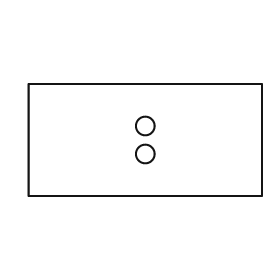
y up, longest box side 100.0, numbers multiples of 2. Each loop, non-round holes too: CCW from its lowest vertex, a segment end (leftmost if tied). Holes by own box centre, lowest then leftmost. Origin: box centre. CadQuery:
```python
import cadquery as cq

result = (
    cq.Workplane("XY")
    .moveTo(-50.0, -24.0)
    .lineTo(50.0, -24.0)
    .lineTo(50.0, 24.0)
    .lineTo(-50.0, 24.0)
    .close()
    .moveTo(0.0, -6.0)
    .circle(4.0)
    .moveTo(0.0, 6.0)
    .circle(4.0)
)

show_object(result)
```